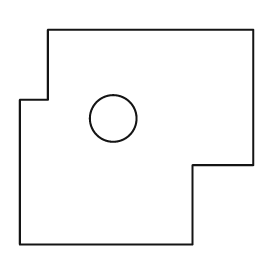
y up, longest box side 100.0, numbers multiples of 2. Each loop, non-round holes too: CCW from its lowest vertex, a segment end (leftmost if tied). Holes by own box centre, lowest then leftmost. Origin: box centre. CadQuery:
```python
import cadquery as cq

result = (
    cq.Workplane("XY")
    .moveTo(-50.0, -46.0)
    .lineTo(24.0, -46.0)
    .lineTo(24.0, -12.0)
    .lineTo(50.0, -12.0)
    .lineTo(50.0, 46.0)
    .lineTo(-38.0, 46.0)
    .lineTo(-38.0, 16.0)
    .lineTo(-50.0, 16.0)
    .close()
    .moveTo(-10.0, 8.0)
    .circle(10.0)
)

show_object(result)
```